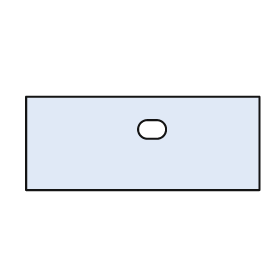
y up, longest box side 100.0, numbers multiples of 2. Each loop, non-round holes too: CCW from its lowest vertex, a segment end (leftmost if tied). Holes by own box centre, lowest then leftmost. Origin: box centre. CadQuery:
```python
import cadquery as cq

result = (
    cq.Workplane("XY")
    .moveTo(-50.0, -20.0)
    .lineTo(50.0, -20.0)
    .lineTo(50.0, 20.0)
    .lineTo(-50.0, 20.0)
    .close()
    .moveTo(2.0, 2.0)
    .lineTo(6.0, 2.0)
    .threePointArc((10.0, 6.0), (6.0, 10.0))
    .lineTo(2.0, 10.0)
    .threePointArc((-2.0, 6.0), (2.0, 2.0))
    .close()
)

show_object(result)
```